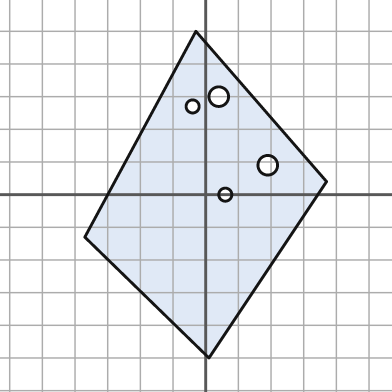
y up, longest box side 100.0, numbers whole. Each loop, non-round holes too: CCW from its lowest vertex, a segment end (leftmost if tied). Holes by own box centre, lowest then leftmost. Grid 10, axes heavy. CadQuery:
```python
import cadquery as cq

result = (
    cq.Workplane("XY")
    .moveTo(1.0, -50.0)
    .lineTo(37.0, 4.0)
    .lineTo(-3.0, 50.0)
    .lineTo(-37.0, -13.0)
    .close()
    .moveTo(6.0, 0.0)
    .circle(2.0)
    .moveTo(19.0, 9.0)
    .circle(3.0)
    .moveTo(-4.0, 27.0)
    .circle(2.0)
    .moveTo(4.0, 30.0)
    .circle(3.0)
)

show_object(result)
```